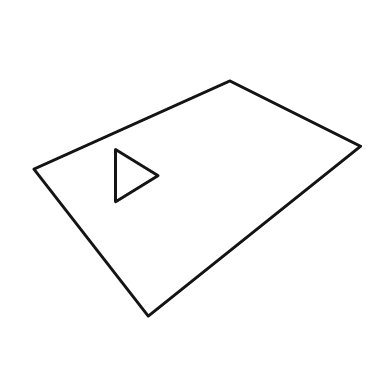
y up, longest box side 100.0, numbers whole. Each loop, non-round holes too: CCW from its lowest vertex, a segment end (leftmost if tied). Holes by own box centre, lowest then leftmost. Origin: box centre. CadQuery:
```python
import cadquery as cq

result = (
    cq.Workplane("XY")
    .moveTo(-15.0, -36.0)
    .lineTo(50.0, 16.0)
    .lineTo(10.0, 36.0)
    .lineTo(-50.0, 9.0)
    .close()
    .moveTo(-25.0, -1.0)
    .lineTo(-12.0, 7.0)
    .lineTo(-25.0, 15.0)
    .close()
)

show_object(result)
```